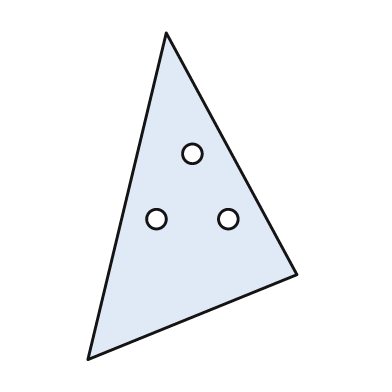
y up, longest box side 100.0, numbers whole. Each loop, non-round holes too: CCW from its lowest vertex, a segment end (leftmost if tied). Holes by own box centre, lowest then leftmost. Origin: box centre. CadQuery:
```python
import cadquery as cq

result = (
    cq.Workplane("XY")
    .moveTo(-32.0, -50.0)
    .lineTo(32.0, -24.0)
    .lineTo(-8.0, 50.0)
    .close()
    .moveTo(-11.0, -7.0)
    .circle(3.0)
    .moveTo(11.0, -7.0)
    .circle(3.0)
    .moveTo(0.0, 13.0)
    .circle(3.0)
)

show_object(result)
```